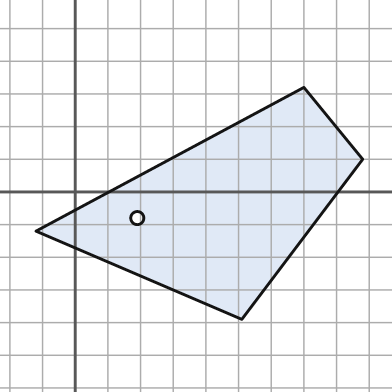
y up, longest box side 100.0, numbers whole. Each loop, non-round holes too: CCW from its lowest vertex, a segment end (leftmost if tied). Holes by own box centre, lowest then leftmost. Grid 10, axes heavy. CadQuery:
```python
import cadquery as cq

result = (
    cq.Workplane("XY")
    .moveTo(51.0, -39.0)
    .lineTo(88.0, 10.0)
    .lineTo(70.0, 32.0)
    .lineTo(-12.0, -12.0)
    .close()
    .moveTo(19.0, -8.0)
    .circle(2.0)
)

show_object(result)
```